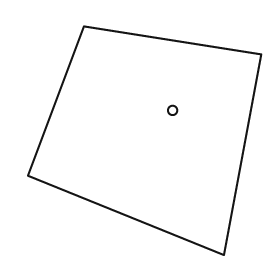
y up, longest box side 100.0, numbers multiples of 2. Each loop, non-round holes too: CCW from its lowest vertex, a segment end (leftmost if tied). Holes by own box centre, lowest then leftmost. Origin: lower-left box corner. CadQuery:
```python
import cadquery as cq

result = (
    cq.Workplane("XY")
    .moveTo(84.0, 0.0)
    .lineTo(100.0, 86.0)
    .lineTo(24.0, 98.0)
    .lineTo(0.0, 34.0)
    .close()
    .moveTo(62.0, 62.0)
    .circle(2.0)
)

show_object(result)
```